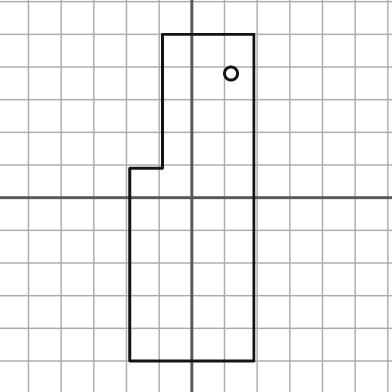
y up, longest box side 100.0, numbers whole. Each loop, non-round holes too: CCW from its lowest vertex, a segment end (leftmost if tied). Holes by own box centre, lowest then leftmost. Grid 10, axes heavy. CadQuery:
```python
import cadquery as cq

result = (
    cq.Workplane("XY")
    .moveTo(-19.0, -50.0)
    .lineTo(19.0, -50.0)
    .lineTo(19.0, 50.0)
    .lineTo(-9.0, 50.0)
    .lineTo(-9.0, 9.0)
    .lineTo(-19.0, 9.0)
    .close()
    .moveTo(12.0, 38.0)
    .circle(2.0)
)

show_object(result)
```